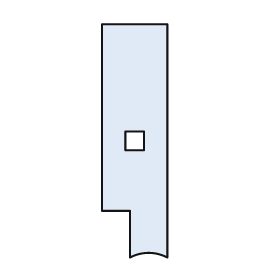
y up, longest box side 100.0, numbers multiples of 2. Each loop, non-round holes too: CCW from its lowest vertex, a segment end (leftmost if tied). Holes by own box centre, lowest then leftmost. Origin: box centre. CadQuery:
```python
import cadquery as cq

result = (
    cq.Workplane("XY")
    .moveTo(-2.0, -50.0)
    .threePointArc((6.0, -48.0), (14.0, -50.0))
    .lineTo(14.0, 50.0)
    .lineTo(-14.0, 50.0)
    .lineTo(-14.0, -30.0)
    .lineTo(-2.0, -30.0)
    .close()
    .moveTo(-4.0, -4.0)
    .lineTo(4.0, -4.0)
    .lineTo(4.0, 4.0)
    .lineTo(-4.0, 4.0)
    .close()
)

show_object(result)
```